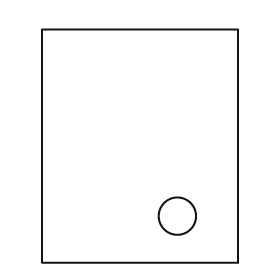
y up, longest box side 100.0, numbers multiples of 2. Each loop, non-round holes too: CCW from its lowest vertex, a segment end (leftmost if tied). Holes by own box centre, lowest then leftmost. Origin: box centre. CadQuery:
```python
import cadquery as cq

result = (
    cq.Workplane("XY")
    .moveTo(-42.0, -50.0)
    .lineTo(42.0, -50.0)
    .lineTo(42.0, 50.0)
    .lineTo(-42.0, 50.0)
    .close()
    .moveTo(16.0, -30.0)
    .circle(8.0)
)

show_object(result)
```